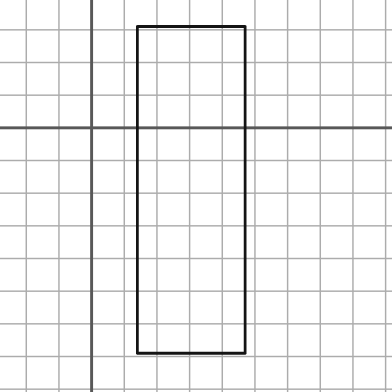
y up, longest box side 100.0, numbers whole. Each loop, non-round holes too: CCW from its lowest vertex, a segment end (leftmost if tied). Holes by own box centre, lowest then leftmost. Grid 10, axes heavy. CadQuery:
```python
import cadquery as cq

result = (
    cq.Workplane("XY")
    .moveTo(14.0, -69.0)
    .lineTo(47.0, -69.0)
    .lineTo(47.0, 31.0)
    .lineTo(14.0, 31.0)
    .close()
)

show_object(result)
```